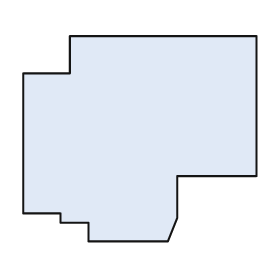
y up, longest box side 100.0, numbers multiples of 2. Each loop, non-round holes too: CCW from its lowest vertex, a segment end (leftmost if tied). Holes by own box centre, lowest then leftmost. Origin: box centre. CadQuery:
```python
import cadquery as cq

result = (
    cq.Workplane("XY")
    .moveTo(-22.0, -44.0)
    .lineTo(12.0, -44.0)
    .lineTo(16.0, -34.0)
    .lineTo(16.0, -16.0)
    .lineTo(50.0, -16.0)
    .lineTo(50.0, 44.0)
    .lineTo(-30.0, 44.0)
    .lineTo(-30.0, 28.0)
    .lineTo(-50.0, 28.0)
    .lineTo(-50.0, -32.0)
    .lineTo(-34.0, -32.0)
    .lineTo(-34.0, -36.0)
    .lineTo(-22.0, -36.0)
    .close()
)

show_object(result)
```